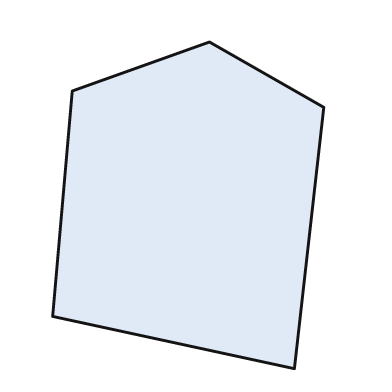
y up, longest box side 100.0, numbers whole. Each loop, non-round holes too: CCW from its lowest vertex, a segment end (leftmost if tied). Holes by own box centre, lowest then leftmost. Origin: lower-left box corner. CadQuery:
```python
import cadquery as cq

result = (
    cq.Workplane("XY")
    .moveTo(74.0, 0.0)
    .lineTo(83.0, 80.0)
    .lineTo(48.0, 100.0)
    .lineTo(6.0, 85.0)
    .lineTo(0.0, 16.0)
    .close()
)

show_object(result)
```